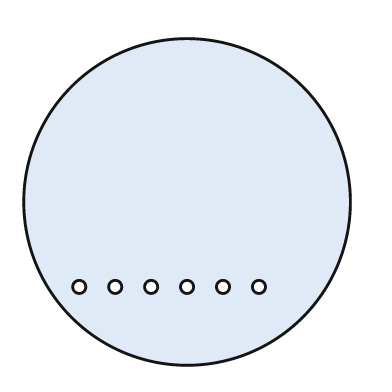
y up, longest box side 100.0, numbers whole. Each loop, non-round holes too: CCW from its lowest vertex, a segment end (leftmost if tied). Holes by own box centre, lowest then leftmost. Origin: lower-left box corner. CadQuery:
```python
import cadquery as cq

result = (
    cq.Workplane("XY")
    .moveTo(50.0, 50.0)
    .circle(50.0)
    .moveTo(17.0, 24.0)
    .circle(2.0)
    .moveTo(28.0, 24.0)
    .circle(2.0)
    .moveTo(39.0, 24.0)
    .circle(2.0)
    .moveTo(50.0, 24.0)
    .circle(2.0)
    .moveTo(61.0, 24.0)
    .circle(2.0)
    .moveTo(72.0, 24.0)
    .circle(2.0)
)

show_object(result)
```